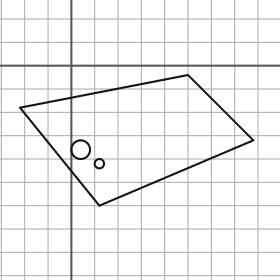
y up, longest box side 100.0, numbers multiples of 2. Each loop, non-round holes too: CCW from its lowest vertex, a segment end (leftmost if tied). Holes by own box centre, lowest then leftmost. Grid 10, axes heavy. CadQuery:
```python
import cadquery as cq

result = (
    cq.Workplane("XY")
    .moveTo(12.0, -60.0)
    .lineTo(78.0, -32.0)
    .lineTo(50.0, -4.0)
    .lineTo(-22.0, -18.0)
    .close()
    .moveTo(12.0, -42.0)
    .circle(2.0)
    .moveTo(4.0, -36.0)
    .circle(4.0)
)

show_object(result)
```